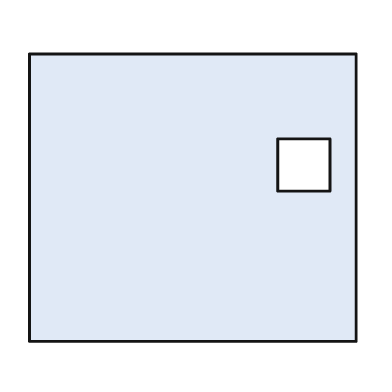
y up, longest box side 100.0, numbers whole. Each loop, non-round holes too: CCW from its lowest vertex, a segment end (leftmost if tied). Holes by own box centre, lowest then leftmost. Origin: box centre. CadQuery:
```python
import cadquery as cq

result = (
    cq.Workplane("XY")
    .moveTo(-50.0, -44.0)
    .lineTo(50.0, -44.0)
    .lineTo(50.0, 44.0)
    .lineTo(-50.0, 44.0)
    .close()
    .moveTo(26.0, 2.0)
    .lineTo(42.0, 2.0)
    .lineTo(42.0, 18.0)
    .lineTo(26.0, 18.0)
    .close()
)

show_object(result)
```